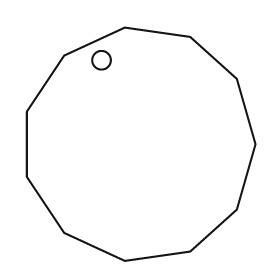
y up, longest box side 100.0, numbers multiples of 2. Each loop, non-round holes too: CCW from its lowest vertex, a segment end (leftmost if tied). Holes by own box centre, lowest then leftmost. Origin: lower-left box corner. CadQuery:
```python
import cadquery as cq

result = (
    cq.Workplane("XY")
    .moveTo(42.0, 0.0)
    .lineTo(70.0, 4.0)
    .lineTo(90.0, 22.0)
    .lineTo(98.0, 50.0)
    .lineTo(90.0, 78.0)
    .lineTo(70.0, 96.0)
    .lineTo(42.0, 100.0)
    .lineTo(16.0, 88.0)
    .lineTo(0.0, 64.0)
    .lineTo(0.0, 36.0)
    .lineTo(16.0, 12.0)
    .close()
    .moveTo(32.0, 86.0)
    .circle(4.0)
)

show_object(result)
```